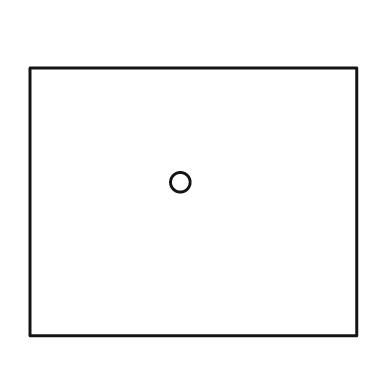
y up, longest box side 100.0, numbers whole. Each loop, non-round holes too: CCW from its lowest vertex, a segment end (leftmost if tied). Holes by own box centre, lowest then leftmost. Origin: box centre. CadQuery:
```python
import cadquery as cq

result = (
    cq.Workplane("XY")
    .moveTo(-50.0, -41.0)
    .lineTo(50.0, -41.0)
    .lineTo(50.0, 41.0)
    .lineTo(-50.0, 41.0)
    .close()
    .moveTo(-4.0, 6.0)
    .circle(3.0)
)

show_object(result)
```